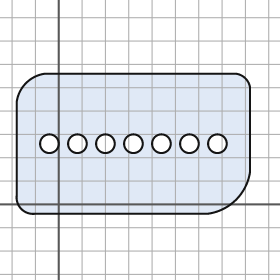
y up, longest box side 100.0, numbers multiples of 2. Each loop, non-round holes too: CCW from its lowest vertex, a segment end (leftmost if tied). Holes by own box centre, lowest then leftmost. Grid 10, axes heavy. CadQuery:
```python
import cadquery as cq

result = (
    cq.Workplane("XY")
    .moveTo(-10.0, -4.0)
    .lineTo(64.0, -4.0)
    .threePointArc((76.0, 2.0), (82.0, 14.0))
    .lineTo(82.0, 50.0)
    .threePointArc((80.0, 54.0), (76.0, 56.0))
    .lineTo(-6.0, 56.0)
    .threePointArc((-14.0, 52.0), (-18.0, 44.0))
    .lineTo(-18.0, 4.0)
    .threePointArc((-16.0, -2.0), (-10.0, -4.0))
    .close()
    .moveTo(-4.0, 26.0)
    .circle(4.0)
    .moveTo(8.0, 26.0)
    .circle(4.0)
    .moveTo(20.0, 26.0)
    .circle(4.0)
    .moveTo(32.0, 26.0)
    .circle(4.0)
    .moveTo(44.0, 26.0)
    .circle(4.0)
    .moveTo(56.0, 26.0)
    .circle(4.0)
    .moveTo(68.0, 26.0)
    .circle(4.0)
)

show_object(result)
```